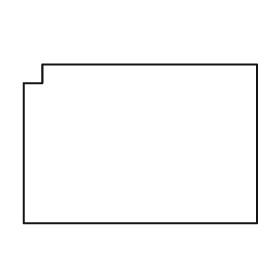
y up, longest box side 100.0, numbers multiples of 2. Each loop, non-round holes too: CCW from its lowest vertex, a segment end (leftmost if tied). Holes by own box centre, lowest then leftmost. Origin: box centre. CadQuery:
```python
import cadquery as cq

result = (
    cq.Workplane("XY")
    .moveTo(-50.0, -34.0)
    .lineTo(50.0, -34.0)
    .lineTo(50.0, 34.0)
    .lineTo(-42.0, 34.0)
    .lineTo(-42.0, 26.0)
    .lineTo(-50.0, 26.0)
    .close()
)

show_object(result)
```